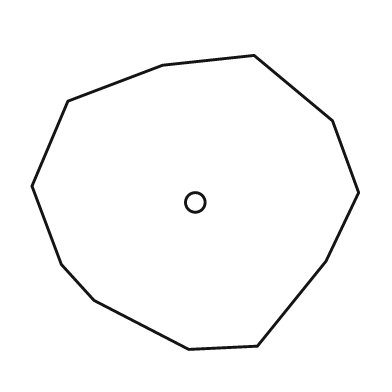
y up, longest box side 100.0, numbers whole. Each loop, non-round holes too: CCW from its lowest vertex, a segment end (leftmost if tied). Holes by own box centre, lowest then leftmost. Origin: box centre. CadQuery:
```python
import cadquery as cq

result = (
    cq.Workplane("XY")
    .moveTo(-2.0, -45.0)
    .lineTo(19.0, -44.0)
    .lineTo(40.0, -18.0)
    .lineTo(50.0, 3.0)
    .lineTo(42.0, 25.0)
    .lineTo(18.0, 45.0)
    .lineTo(-10.0, 42.0)
    .lineTo(-39.0, 31.0)
    .lineTo(-50.0, 5.0)
    .lineTo(-41.0, -19.0)
    .lineTo(-31.0, -30.0)
    .close()
    .moveTo(0.0, 0.0)
    .circle(3.0)
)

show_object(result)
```